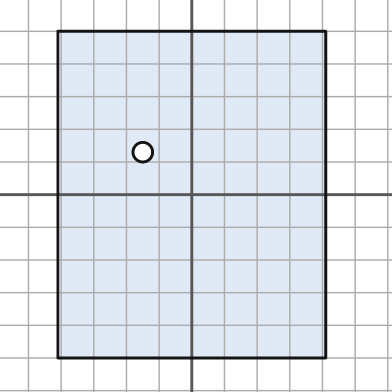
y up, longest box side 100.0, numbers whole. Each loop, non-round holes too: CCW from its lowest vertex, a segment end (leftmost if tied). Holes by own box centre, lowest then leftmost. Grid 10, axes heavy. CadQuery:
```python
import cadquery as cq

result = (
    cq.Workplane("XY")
    .moveTo(-41.0, -50.0)
    .lineTo(41.0, -50.0)
    .lineTo(41.0, 50.0)
    .lineTo(-41.0, 50.0)
    .close()
    .moveTo(-15.0, 13.0)
    .circle(3.0)
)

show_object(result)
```